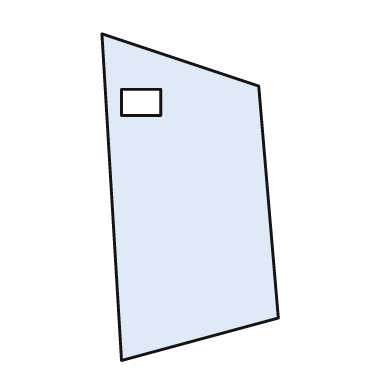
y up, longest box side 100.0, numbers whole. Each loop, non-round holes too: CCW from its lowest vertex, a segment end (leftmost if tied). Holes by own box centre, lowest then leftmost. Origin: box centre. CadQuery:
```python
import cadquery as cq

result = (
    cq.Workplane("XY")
    .moveTo(-21.0, -50.0)
    .lineTo(27.0, -37.0)
    .lineTo(21.0, 34.0)
    .lineTo(-27.0, 50.0)
    .close()
    .moveTo(-21.0, 25.0)
    .lineTo(-9.0, 25.0)
    .lineTo(-9.0, 33.0)
    .lineTo(-21.0, 33.0)
    .close()
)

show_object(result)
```